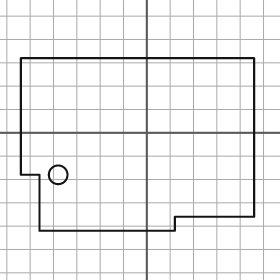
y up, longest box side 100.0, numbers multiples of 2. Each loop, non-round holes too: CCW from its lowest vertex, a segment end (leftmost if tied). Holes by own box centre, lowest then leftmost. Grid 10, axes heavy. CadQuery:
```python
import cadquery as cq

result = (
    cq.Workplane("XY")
    .moveTo(-46.0, -42.0)
    .lineTo(12.0, -42.0)
    .lineTo(12.0, -36.0)
    .lineTo(46.0, -36.0)
    .lineTo(46.0, 32.0)
    .lineTo(-54.0, 32.0)
    .lineTo(-54.0, -18.0)
    .lineTo(-46.0, -18.0)
    .close()
    .moveTo(-38.0, -18.0)
    .circle(4.0)
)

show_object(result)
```